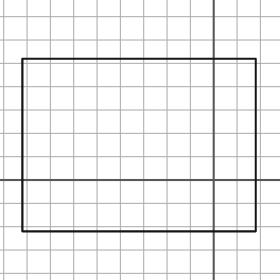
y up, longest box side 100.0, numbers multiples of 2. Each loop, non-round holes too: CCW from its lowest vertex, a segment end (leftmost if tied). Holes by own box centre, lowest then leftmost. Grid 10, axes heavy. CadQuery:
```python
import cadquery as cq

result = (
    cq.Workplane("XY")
    .moveTo(-82.0, -22.0)
    .lineTo(18.0, -22.0)
    .lineTo(18.0, 52.0)
    .lineTo(-82.0, 52.0)
    .close()
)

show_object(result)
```